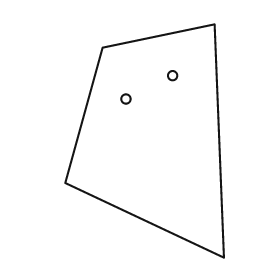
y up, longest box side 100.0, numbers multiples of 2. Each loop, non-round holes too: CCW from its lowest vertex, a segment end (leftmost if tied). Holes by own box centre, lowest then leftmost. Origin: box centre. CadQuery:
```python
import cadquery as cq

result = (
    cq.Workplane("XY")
    .moveTo(34.0, -50.0)
    .lineTo(30.0, 50.0)
    .lineTo(-18.0, 40.0)
    .lineTo(-34.0, -18.0)
    .close()
    .moveTo(-8.0, 18.0)
    .circle(2.0)
    .moveTo(12.0, 28.0)
    .circle(2.0)
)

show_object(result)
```